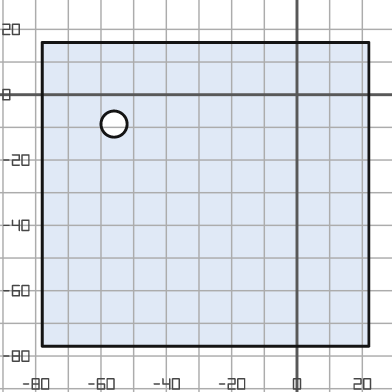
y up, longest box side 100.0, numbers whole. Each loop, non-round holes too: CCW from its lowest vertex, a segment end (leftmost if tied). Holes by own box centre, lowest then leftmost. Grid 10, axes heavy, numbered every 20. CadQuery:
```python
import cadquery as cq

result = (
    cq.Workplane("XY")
    .moveTo(-78.0, -77.0)
    .lineTo(22.0, -77.0)
    .lineTo(22.0, 16.0)
    .lineTo(-78.0, 16.0)
    .close()
    .moveTo(-56.0, -9.0)
    .circle(4.0)
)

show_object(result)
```